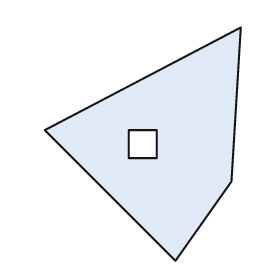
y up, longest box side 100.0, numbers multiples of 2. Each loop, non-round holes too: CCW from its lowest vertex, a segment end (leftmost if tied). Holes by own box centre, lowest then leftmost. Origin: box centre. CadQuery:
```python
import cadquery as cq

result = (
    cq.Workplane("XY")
    .moveTo(14.0, -50.0)
    .lineTo(38.0, -16.0)
    .lineTo(42.0, 50.0)
    .lineTo(-42.0, 6.0)
    .close()
    .moveTo(-6.0, -6.0)
    .lineTo(6.0, -6.0)
    .lineTo(6.0, 6.0)
    .lineTo(-6.0, 6.0)
    .close()
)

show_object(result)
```